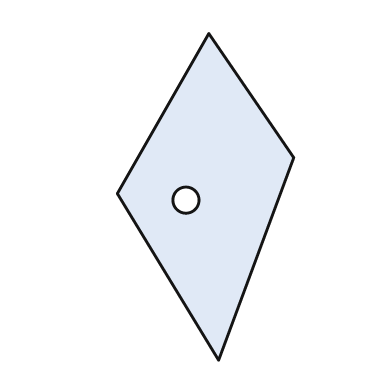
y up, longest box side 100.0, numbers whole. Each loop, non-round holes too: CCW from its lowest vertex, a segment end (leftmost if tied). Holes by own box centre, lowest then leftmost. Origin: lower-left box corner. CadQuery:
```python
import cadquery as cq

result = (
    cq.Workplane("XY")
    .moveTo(31.0, 0.0)
    .lineTo(54.0, 62.0)
    .lineTo(28.0, 100.0)
    .lineTo(0.0, 51.0)
    .close()
    .moveTo(21.0, 49.0)
    .circle(4.0)
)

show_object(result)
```